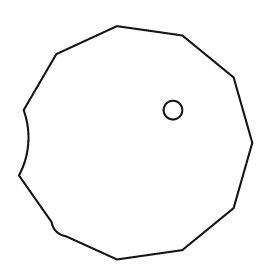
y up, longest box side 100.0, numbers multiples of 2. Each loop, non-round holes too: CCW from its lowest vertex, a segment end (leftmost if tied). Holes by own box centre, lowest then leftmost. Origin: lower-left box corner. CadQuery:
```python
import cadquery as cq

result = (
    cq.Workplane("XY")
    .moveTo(42.0, 0.0)
    .lineTo(70.0, 4.0)
    .lineTo(92.0, 22.0)
    .lineTo(100.0, 50.0)
    .lineTo(92.0, 78.0)
    .lineTo(70.0, 96.0)
    .lineTo(42.0, 100.0)
    .lineTo(16.0, 88.0)
    .lineTo(2.0, 64.0)
    .threePointArc((4.0, 50.0), (0.0, 36.0))
    .lineTo(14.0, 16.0)
    .threePointArc((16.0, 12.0), (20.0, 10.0))
    .close()
    .moveTo(66.0, 64.0)
    .circle(4.0)
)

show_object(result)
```